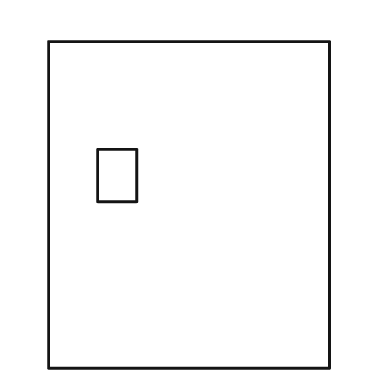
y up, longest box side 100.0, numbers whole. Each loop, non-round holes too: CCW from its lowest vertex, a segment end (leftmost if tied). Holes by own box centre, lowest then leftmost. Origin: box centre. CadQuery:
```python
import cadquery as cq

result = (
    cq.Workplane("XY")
    .moveTo(-43.0, -50.0)
    .lineTo(43.0, -50.0)
    .lineTo(43.0, 50.0)
    .lineTo(-43.0, 50.0)
    .close()
    .moveTo(-28.0, 1.0)
    .lineTo(-16.0, 1.0)
    .lineTo(-16.0, 17.0)
    .lineTo(-28.0, 17.0)
    .close()
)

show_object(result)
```